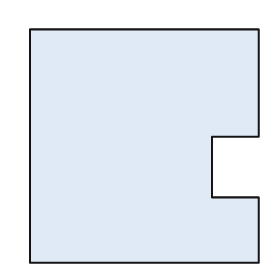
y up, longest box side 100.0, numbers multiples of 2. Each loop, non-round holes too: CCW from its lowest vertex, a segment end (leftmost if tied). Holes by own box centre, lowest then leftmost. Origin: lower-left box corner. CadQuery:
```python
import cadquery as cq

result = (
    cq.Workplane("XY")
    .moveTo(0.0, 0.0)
    .lineTo(98.0, 0.0)
    .lineTo(98.0, 28.0)
    .lineTo(78.0, 28.0)
    .lineTo(78.0, 54.0)
    .lineTo(98.0, 54.0)
    .lineTo(98.0, 100.0)
    .lineTo(0.0, 100.0)
    .close()
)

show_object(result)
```